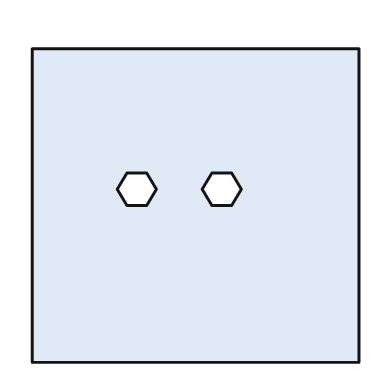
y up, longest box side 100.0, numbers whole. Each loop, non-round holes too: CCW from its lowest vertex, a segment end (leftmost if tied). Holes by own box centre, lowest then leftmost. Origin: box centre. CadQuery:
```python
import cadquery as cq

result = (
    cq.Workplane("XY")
    .moveTo(-50.0, -48.0)
    .lineTo(50.0, -48.0)
    .lineTo(50.0, 48.0)
    .lineTo(-50.0, 48.0)
    .close()
    .moveTo(-21.0, 0.0)
    .lineTo(-15.0, 0.0)
    .lineTo(-12.0, 5.0)
    .lineTo(-15.0, 10.0)
    .lineTo(-21.0, 10.0)
    .lineTo(-24.0, 5.0)
    .close()
    .moveTo(5.0, 0.0)
    .lineTo(11.0, 0.0)
    .lineTo(14.0, 5.0)
    .lineTo(11.0, 10.0)
    .lineTo(5.0, 10.0)
    .lineTo(2.0, 5.0)
    .close()
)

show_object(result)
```